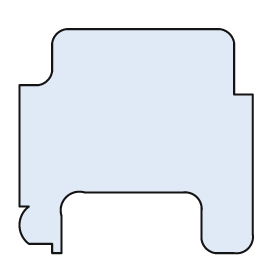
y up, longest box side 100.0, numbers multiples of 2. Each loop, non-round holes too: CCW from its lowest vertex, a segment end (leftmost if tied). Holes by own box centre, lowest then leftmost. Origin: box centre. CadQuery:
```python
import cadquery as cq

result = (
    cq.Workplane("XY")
    .moveTo(-36.0, -48.0)
    .lineTo(-32.0, -48.0)
    .lineTo(-32.0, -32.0)
    .threePointArc((-30.0, -24.0), (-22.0, -22.0))
    .lineTo(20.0, -22.0)
    .threePointArc((26.0, -24.0), (28.0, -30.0))
    .lineTo(28.0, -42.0)
    .threePointArc((30.0, -46.0), (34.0, -48.0))
    .lineTo(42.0, -48.0)
    .threePointArc((48.0, -46.0), (50.0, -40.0))
    .lineTo(50.0, 20.0)
    .lineTo(42.0, 20.0)
    .lineTo(42.0, 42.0)
    .threePointArc((40.0, 46.0), (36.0, 48.0))
    .lineTo(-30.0, 48.0)
    .threePointArc((-34.0, 46.0), (-36.0, 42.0))
    .lineTo(-36.0, 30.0)
    .threePointArc((-38.0, 26.0), (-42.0, 24.0))
    .lineTo(-50.0, 24.0)
    .lineTo(-50.0, -28.0)
    .lineTo(-46.0, -28.0)
    .threePointArc((-50.0, -36.0), (-46.0, -44.0))
    .lineTo(-36.0, -44.0)
    .close()
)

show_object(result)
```